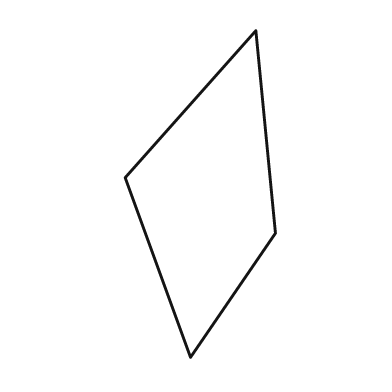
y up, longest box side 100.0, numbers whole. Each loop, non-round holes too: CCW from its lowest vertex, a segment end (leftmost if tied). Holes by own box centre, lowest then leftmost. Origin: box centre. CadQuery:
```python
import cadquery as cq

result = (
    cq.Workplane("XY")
    .moveTo(-3.0, -50.0)
    .lineTo(23.0, -12.0)
    .lineTo(17.0, 50.0)
    .lineTo(-23.0, 5.0)
    .close()
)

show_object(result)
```